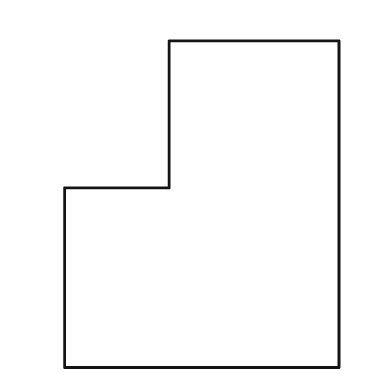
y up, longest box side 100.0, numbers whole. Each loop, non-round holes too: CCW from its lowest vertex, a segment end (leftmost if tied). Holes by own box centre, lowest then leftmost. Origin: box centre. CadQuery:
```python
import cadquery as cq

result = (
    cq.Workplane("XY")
    .moveTo(-42.0, -50.0)
    .lineTo(42.0, -50.0)
    .lineTo(42.0, 50.0)
    .lineTo(-10.0, 50.0)
    .lineTo(-10.0, 5.0)
    .lineTo(-42.0, 5.0)
    .close()
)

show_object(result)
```